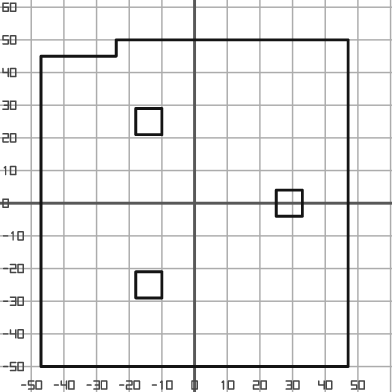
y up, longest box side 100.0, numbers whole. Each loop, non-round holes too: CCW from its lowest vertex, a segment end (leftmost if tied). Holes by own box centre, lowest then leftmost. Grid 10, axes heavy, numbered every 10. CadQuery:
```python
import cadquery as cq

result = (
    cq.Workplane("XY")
    .moveTo(-47.0, -50.0)
    .lineTo(47.0, -50.0)
    .lineTo(47.0, 50.0)
    .lineTo(-24.0, 50.0)
    .lineTo(-24.0, 45.0)
    .lineTo(-47.0, 45.0)
    .close()
    .moveTo(-18.0, -29.0)
    .lineTo(-10.0, -29.0)
    .lineTo(-10.0, -21.0)
    .lineTo(-18.0, -21.0)
    .close()
    .moveTo(25.0, -4.0)
    .lineTo(33.0, -4.0)
    .lineTo(33.0, 4.0)
    .lineTo(25.0, 4.0)
    .close()
    .moveTo(-18.0, 21.0)
    .lineTo(-10.0, 21.0)
    .lineTo(-10.0, 29.0)
    .lineTo(-18.0, 29.0)
    .close()
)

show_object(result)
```